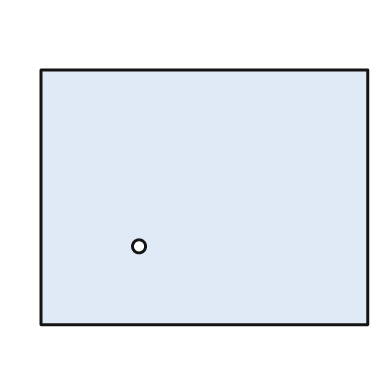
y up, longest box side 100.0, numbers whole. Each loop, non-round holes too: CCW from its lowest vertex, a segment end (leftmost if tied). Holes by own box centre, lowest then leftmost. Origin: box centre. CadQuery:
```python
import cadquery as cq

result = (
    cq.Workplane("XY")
    .moveTo(-50.0, -39.0)
    .lineTo(50.0, -39.0)
    .lineTo(50.0, 39.0)
    .lineTo(-50.0, 39.0)
    .close()
    .moveTo(-20.0, -15.0)
    .circle(2.0)
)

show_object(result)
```